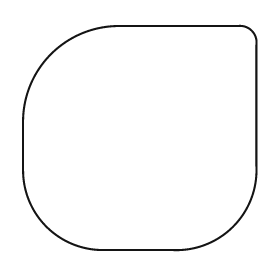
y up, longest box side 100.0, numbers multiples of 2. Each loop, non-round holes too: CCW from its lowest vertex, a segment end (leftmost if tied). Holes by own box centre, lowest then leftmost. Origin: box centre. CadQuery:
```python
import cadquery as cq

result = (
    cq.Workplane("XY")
    .moveTo(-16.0, -48.0)
    .lineTo(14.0, -48.0)
    .threePointArc((40.0, -38.0), (50.0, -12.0))
    .lineTo(50.0, 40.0)
    .threePointArc((48.0, 46.0), (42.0, 48.0))
    .lineTo(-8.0, 48.0)
    .threePointArc((-38.0, 36.0), (-50.0, 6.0))
    .lineTo(-50.0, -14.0)
    .threePointArc((-40.0, -38.0), (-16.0, -48.0))
    .close()
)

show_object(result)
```